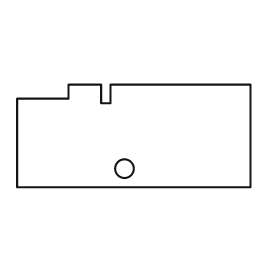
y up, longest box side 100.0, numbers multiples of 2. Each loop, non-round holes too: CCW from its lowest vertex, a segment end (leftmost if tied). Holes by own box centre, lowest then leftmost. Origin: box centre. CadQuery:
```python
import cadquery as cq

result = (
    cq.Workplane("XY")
    .moveTo(-50.0, -22.0)
    .lineTo(50.0, -22.0)
    .lineTo(50.0, 22.0)
    .lineTo(-10.0, 22.0)
    .lineTo(-10.0, 14.0)
    .lineTo(-14.0, 14.0)
    .lineTo(-14.0, 22.0)
    .lineTo(-28.0, 22.0)
    .lineTo(-28.0, 16.0)
    .lineTo(-50.0, 16.0)
    .close()
    .moveTo(-4.0, -14.0)
    .circle(4.0)
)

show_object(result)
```